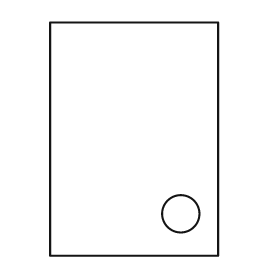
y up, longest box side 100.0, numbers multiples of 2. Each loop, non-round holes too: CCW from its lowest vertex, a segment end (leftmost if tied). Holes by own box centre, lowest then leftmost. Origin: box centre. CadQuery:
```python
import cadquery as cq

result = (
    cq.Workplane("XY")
    .moveTo(-36.0, -50.0)
    .lineTo(36.0, -50.0)
    .lineTo(36.0, 50.0)
    .lineTo(-36.0, 50.0)
    .close()
    .moveTo(20.0, -32.0)
    .circle(8.0)
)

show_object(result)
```